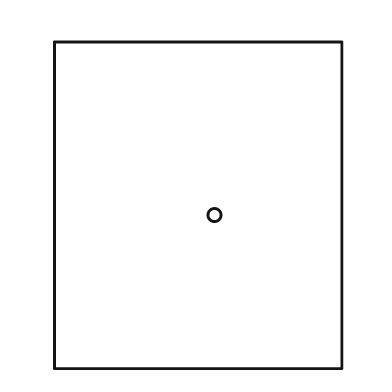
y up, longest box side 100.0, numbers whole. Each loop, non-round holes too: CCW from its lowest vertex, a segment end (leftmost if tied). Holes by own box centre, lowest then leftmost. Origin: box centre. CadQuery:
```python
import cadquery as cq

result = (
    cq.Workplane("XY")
    .moveTo(-44.0, -50.0)
    .lineTo(44.0, -50.0)
    .lineTo(44.0, 50.0)
    .lineTo(-44.0, 50.0)
    .close()
    .moveTo(5.0, -3.0)
    .circle(2.0)
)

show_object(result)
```